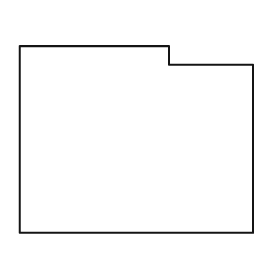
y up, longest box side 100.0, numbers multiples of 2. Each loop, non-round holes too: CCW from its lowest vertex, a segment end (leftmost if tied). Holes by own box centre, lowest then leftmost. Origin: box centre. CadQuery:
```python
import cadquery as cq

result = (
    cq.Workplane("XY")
    .moveTo(-50.0, -40.0)
    .lineTo(50.0, -40.0)
    .lineTo(50.0, 32.0)
    .lineTo(14.0, 32.0)
    .lineTo(14.0, 40.0)
    .lineTo(-50.0, 40.0)
    .close()
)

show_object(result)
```